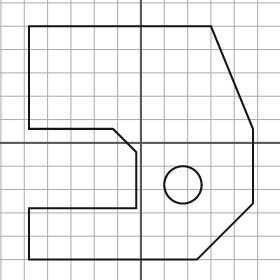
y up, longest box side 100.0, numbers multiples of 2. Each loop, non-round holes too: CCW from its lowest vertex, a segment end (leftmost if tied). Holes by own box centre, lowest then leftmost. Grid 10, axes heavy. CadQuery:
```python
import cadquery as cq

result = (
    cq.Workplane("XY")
    .moveTo(-48.0, -50.0)
    .lineTo(24.0, -50.0)
    .lineTo(48.0, -26.0)
    .lineTo(48.0, 6.0)
    .lineTo(30.0, 50.0)
    .lineTo(-48.0, 50.0)
    .lineTo(-48.0, 6.0)
    .lineTo(-12.0, 6.0)
    .lineTo(-2.0, -4.0)
    .lineTo(-2.0, -28.0)
    .lineTo(-48.0, -28.0)
    .close()
    .moveTo(18.0, -18.0)
    .circle(8.0)
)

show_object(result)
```